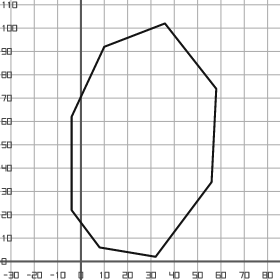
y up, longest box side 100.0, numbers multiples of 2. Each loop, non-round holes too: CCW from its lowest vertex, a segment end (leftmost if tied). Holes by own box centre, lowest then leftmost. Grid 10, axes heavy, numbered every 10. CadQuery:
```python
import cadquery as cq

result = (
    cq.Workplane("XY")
    .moveTo(32.0, 2.0)
    .lineTo(56.0, 34.0)
    .lineTo(58.0, 74.0)
    .lineTo(36.0, 102.0)
    .lineTo(10.0, 92.0)
    .lineTo(-4.0, 62.0)
    .lineTo(-4.0, 22.0)
    .lineTo(8.0, 6.0)
    .close()
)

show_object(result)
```